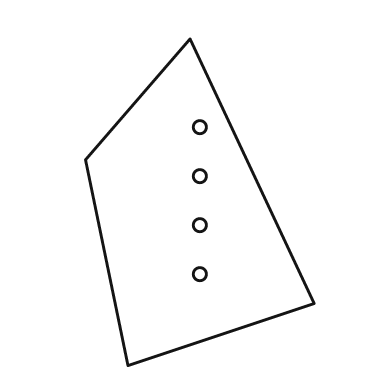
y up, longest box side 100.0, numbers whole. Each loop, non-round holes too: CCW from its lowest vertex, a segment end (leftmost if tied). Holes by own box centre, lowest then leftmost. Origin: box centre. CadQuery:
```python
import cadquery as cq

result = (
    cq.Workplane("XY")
    .moveTo(-22.0, -50.0)
    .lineTo(35.0, -31.0)
    .lineTo(-3.0, 50.0)
    .lineTo(-35.0, 13.0)
    .close()
    .moveTo(0.0, -22.0)
    .circle(2.0)
    .moveTo(0.0, -7.0)
    .circle(2.0)
    .moveTo(0.0, 8.0)
    .circle(2.0)
    .moveTo(0.0, 23.0)
    .circle(2.0)
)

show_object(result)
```